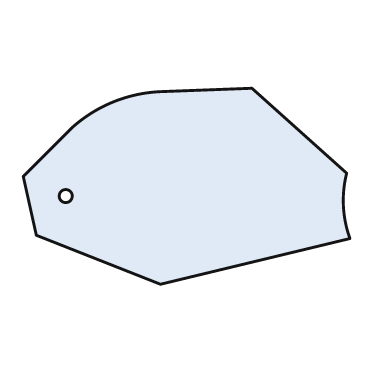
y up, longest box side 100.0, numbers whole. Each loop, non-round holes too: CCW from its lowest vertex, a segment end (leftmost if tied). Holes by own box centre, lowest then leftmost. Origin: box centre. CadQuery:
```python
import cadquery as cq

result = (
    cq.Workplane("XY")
    .moveTo(-8.0, -30.0)
    .lineTo(50.0, -16.0)
    .threePointArc((48.0, -6.0), (49.0, 4.0))
    .lineTo(20.0, 30.0)
    .lineTo(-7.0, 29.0)
    .threePointArc((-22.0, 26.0), (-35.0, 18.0))
    .lineTo(-50.0, 3.0)
    .lineTo(-46.0, -15.0)
    .close()
    .moveTo(-37.0, -3.0)
    .circle(2.0)
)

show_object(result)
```